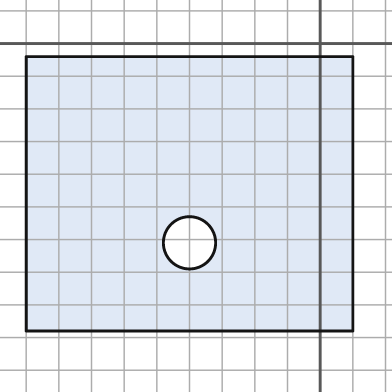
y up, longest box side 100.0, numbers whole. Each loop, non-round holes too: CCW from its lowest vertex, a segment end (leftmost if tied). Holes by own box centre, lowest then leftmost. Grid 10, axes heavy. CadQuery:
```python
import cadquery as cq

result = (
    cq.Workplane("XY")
    .moveTo(-90.0, -88.0)
    .lineTo(10.0, -88.0)
    .lineTo(10.0, -4.0)
    .lineTo(-90.0, -4.0)
    .close()
    .moveTo(-40.0, -61.0)
    .circle(8.0)
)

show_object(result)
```